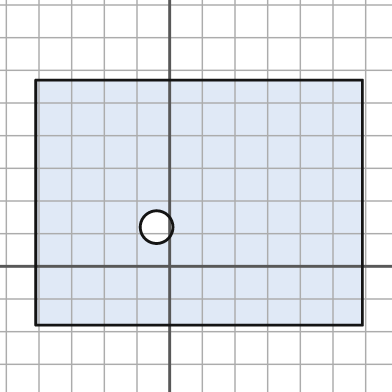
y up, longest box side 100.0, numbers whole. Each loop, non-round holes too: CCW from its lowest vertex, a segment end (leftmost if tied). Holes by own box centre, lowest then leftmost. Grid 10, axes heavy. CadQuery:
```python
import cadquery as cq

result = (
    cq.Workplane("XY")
    .moveTo(-41.0, -18.0)
    .lineTo(59.0, -18.0)
    .lineTo(59.0, 57.0)
    .lineTo(-41.0, 57.0)
    .close()
    .moveTo(-4.0, 12.0)
    .circle(5.0)
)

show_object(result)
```